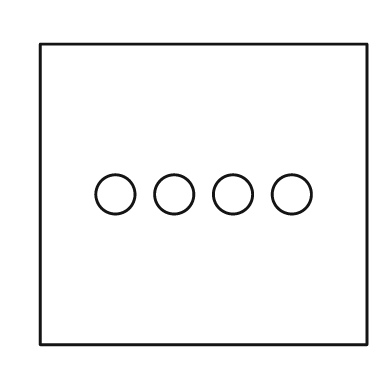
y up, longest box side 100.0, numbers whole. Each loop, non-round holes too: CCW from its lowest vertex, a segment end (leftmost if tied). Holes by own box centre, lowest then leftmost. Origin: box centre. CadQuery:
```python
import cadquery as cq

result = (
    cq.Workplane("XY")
    .moveTo(-50.0, -46.0)
    .lineTo(50.0, -46.0)
    .lineTo(50.0, 46.0)
    .lineTo(-50.0, 46.0)
    .close()
    .moveTo(-27.0, 0.0)
    .circle(6.0)
    .moveTo(-9.0, 0.0)
    .circle(6.0)
    .moveTo(9.0, 0.0)
    .circle(6.0)
    .moveTo(27.0, 0.0)
    .circle(6.0)
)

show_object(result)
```